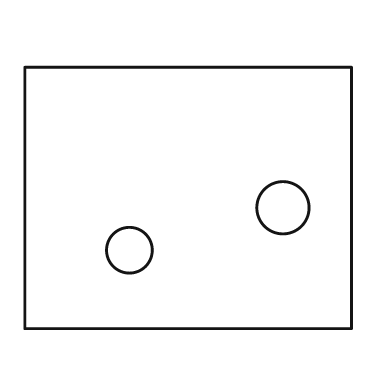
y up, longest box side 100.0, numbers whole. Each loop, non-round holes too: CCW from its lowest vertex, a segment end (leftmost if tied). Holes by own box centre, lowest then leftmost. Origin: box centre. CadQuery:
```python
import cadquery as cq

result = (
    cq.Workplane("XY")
    .moveTo(-50.0, -40.0)
    .lineTo(50.0, -40.0)
    .lineTo(50.0, 40.0)
    .lineTo(-50.0, 40.0)
    .close()
    .moveTo(-18.0, -16.0)
    .circle(7.0)
    .moveTo(29.0, -3.0)
    .circle(8.0)
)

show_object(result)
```